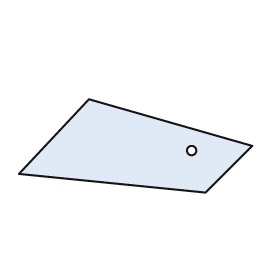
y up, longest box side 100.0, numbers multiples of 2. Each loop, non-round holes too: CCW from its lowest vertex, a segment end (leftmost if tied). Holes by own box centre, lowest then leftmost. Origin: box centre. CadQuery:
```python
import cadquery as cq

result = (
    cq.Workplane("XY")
    .moveTo(30.0, -20.0)
    .lineTo(50.0, 0.0)
    .lineTo(-20.0, 20.0)
    .lineTo(-50.0, -12.0)
    .close()
    .moveTo(24.0, -2.0)
    .circle(2.0)
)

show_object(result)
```